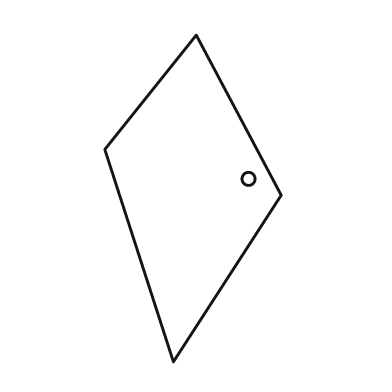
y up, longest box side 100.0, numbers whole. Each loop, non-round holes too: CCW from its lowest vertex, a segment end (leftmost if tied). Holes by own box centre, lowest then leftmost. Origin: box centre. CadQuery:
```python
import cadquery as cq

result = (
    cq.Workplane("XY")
    .moveTo(-6.0, -50.0)
    .lineTo(27.0, 1.0)
    .lineTo(1.0, 50.0)
    .lineTo(-27.0, 15.0)
    .close()
    .moveTo(17.0, 6.0)
    .circle(2.0)
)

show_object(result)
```